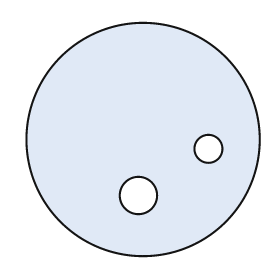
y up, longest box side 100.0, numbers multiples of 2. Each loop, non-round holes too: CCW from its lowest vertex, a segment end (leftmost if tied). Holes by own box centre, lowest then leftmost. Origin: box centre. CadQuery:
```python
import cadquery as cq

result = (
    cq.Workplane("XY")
    .moveTo(0.0, 0.0)
    .circle(50.0)
    .moveTo(-2.0, -24.0)
    .circle(8.0)
    .moveTo(28.0, -4.0)
    .circle(6.0)
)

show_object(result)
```